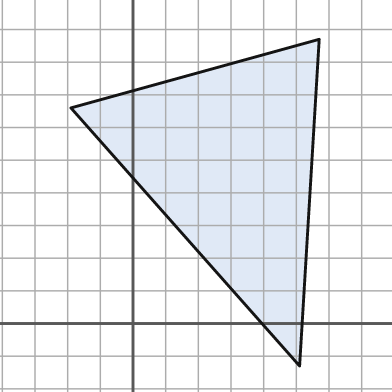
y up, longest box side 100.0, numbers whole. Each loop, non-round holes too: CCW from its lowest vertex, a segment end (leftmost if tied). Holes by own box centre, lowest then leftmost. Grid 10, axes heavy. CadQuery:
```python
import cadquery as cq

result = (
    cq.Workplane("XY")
    .moveTo(51.0, -13.0)
    .lineTo(57.0, 87.0)
    .lineTo(-19.0, 66.0)
    .close()
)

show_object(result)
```